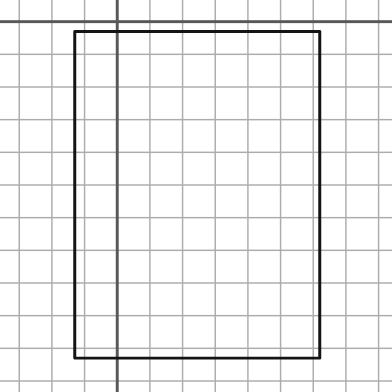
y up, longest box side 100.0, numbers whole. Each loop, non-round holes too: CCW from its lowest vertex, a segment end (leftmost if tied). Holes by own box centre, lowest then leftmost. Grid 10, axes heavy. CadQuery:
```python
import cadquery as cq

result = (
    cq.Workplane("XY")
    .moveTo(-13.0, -103.0)
    .lineTo(62.0, -103.0)
    .lineTo(62.0, -3.0)
    .lineTo(-13.0, -3.0)
    .close()
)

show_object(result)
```